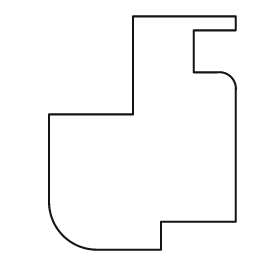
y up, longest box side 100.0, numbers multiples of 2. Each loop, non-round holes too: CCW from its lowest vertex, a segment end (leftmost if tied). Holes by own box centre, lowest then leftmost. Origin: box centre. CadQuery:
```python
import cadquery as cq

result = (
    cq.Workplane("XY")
    .moveTo(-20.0, -50.0)
    .lineTo(8.0, -50.0)
    .lineTo(8.0, -38.0)
    .lineTo(40.0, -38.0)
    .lineTo(40.0, 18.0)
    .threePointArc((38.0, 24.0), (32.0, 26.0))
    .lineTo(22.0, 26.0)
    .lineTo(22.0, 44.0)
    .lineTo(40.0, 44.0)
    .lineTo(40.0, 50.0)
    .lineTo(-4.0, 50.0)
    .lineTo(-4.0, 8.0)
    .lineTo(-40.0, 8.0)
    .lineTo(-40.0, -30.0)
    .threePointArc((-34.0, -44.0), (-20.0, -50.0))
    .close()
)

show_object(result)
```